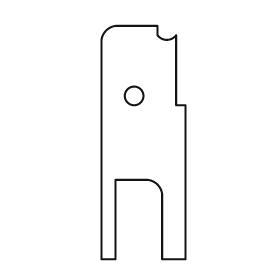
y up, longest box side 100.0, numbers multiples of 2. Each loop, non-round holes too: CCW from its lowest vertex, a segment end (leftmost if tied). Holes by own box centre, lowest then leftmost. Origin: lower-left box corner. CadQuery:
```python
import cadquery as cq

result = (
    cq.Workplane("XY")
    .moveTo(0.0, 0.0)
    .lineTo(6.0, 0.0)
    .lineTo(6.0, 34.0)
    .lineTo(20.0, 34.0)
    .threePointArc((24.0, 32.0), (26.0, 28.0))
    .lineTo(26.0, 0.0)
    .lineTo(36.0, 0.0)
    .lineTo(36.0, 66.0)
    .lineTo(32.0, 66.0)
    .lineTo(32.0, 96.0)
    .threePointArc((28.0, 94.0), (24.0, 96.0))
    .lineTo(24.0, 100.0)
    .lineTo(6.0, 100.0)
    .threePointArc((2.0, 98.0), (0.0, 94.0))
    .close()
    .moveTo(14.0, 70.0)
    .circle(4.0)
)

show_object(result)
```